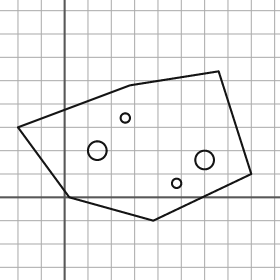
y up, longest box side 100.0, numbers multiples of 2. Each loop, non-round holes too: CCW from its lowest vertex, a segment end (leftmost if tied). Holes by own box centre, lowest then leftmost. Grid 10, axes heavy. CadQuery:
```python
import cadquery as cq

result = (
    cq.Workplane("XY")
    .moveTo(38.0, -10.0)
    .lineTo(80.0, 10.0)
    .lineTo(66.0, 54.0)
    .lineTo(28.0, 48.0)
    .lineTo(-20.0, 30.0)
    .lineTo(2.0, 0.0)
    .close()
    .moveTo(48.0, 6.0)
    .circle(2.0)
    .moveTo(60.0, 16.0)
    .circle(4.0)
    .moveTo(14.0, 20.0)
    .circle(4.0)
    .moveTo(26.0, 34.0)
    .circle(2.0)
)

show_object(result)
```